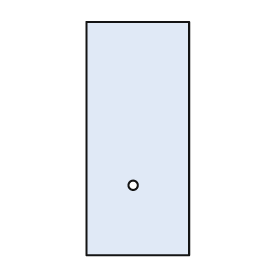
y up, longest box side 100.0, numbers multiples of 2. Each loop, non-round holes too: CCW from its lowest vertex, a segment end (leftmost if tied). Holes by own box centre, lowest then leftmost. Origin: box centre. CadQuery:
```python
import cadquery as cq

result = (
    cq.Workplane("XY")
    .moveTo(-22.0, -50.0)
    .lineTo(22.0, -50.0)
    .lineTo(22.0, 50.0)
    .lineTo(-22.0, 50.0)
    .close()
    .moveTo(-2.0, -20.0)
    .circle(2.0)
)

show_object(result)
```